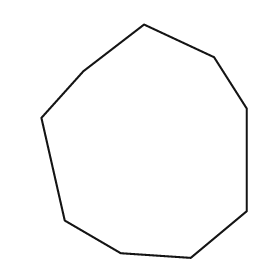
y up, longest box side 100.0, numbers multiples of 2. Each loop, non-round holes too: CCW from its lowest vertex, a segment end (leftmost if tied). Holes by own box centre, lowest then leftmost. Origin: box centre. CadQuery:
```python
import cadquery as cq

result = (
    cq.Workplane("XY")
    .moveTo(20.0, -50.0)
    .lineTo(44.0, -30.0)
    .lineTo(44.0, 14.0)
    .lineTo(30.0, 36.0)
    .lineTo(0.0, 50.0)
    .lineTo(-26.0, 30.0)
    .lineTo(-44.0, 10.0)
    .lineTo(-34.0, -34.0)
    .lineTo(-10.0, -48.0)
    .close()
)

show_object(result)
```